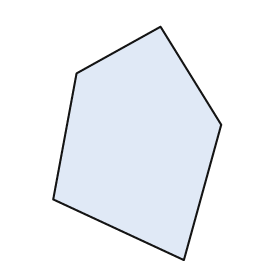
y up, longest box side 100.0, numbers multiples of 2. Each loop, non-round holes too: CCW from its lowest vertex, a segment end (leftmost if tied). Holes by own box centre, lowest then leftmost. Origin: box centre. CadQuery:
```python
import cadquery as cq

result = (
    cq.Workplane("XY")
    .moveTo(20.0, -50.0)
    .lineTo(36.0, 8.0)
    .lineTo(10.0, 50.0)
    .lineTo(-26.0, 30.0)
    .lineTo(-36.0, -24.0)
    .close()
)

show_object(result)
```